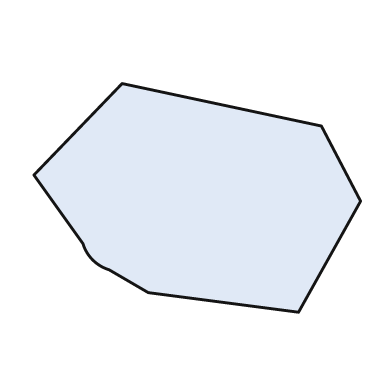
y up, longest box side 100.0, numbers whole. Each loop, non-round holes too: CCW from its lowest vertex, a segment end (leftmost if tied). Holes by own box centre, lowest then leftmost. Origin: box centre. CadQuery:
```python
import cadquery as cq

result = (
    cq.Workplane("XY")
    .moveTo(31.0, -35.0)
    .lineTo(50.0, -1.0)
    .lineTo(38.0, 22.0)
    .lineTo(-23.0, 35.0)
    .lineTo(-50.0, 7.0)
    .lineTo(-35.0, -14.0)
    .threePointArc((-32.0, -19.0), (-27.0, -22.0))
    .lineTo(-15.0, -29.0)
    .close()
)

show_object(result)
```